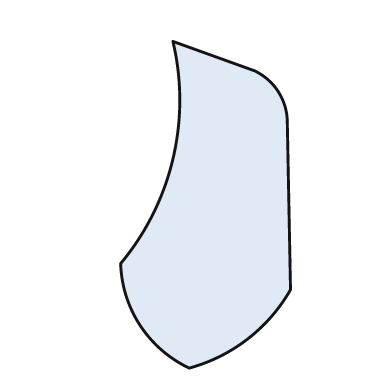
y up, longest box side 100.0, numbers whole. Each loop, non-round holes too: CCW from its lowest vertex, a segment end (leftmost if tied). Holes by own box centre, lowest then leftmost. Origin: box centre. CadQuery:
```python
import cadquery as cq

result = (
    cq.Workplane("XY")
    .moveTo(-5.0, -50.0)
    .threePointArc((13.0, -41.0), (26.0, -26.0))
    .lineTo(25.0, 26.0)
    .threePointArc((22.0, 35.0), (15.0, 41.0))
    .lineTo(-10.0, 50.0)
    .threePointArc((-10.0, 14.0), (-26.0, -18.0))
    .threePointArc((-20.0, -37.0), (-5.0, -50.0))
    .close()
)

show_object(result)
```